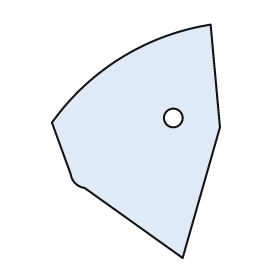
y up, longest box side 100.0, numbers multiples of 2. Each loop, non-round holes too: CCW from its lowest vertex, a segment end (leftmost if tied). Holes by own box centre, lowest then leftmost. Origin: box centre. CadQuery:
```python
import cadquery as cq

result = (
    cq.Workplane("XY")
    .moveTo(20.0, -50.0)
    .lineTo(36.0, 6.0)
    .lineTo(32.0, 50.0)
    .threePointArc((-6.0, 36.0), (-36.0, 8.0))
    .lineTo(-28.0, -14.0)
    .threePointArc((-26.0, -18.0), (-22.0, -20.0))
    .close()
    .moveTo(16.0, 10.0)
    .circle(4.0)
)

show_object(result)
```